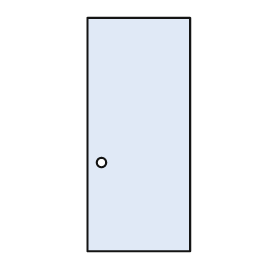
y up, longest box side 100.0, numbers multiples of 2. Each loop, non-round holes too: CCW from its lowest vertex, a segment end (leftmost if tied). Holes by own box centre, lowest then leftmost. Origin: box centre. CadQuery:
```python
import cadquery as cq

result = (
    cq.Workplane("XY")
    .moveTo(-22.0, -50.0)
    .lineTo(22.0, -50.0)
    .lineTo(22.0, 50.0)
    .lineTo(-22.0, 50.0)
    .close()
    .moveTo(-16.0, -12.0)
    .circle(2.0)
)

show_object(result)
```